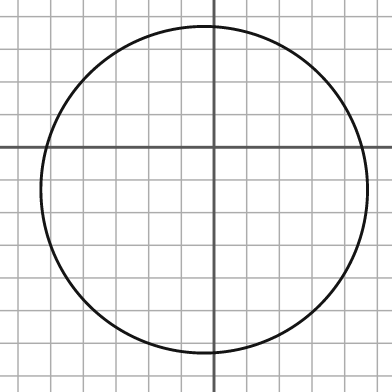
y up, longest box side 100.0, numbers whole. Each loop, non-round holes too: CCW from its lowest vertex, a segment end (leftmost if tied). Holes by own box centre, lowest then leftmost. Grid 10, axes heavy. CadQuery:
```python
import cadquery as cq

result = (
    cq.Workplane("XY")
    .moveTo(-3.0, -13.0)
    .circle(50.0)
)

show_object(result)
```